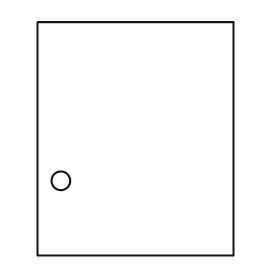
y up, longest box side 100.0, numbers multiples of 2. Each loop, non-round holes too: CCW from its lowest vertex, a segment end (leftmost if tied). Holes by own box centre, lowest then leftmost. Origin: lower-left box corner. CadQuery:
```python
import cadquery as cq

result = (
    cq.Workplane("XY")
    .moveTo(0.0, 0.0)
    .lineTo(84.0, 0.0)
    .lineTo(84.0, 100.0)
    .lineTo(0.0, 100.0)
    .close()
    .moveTo(10.0, 32.0)
    .circle(4.0)
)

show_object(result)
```